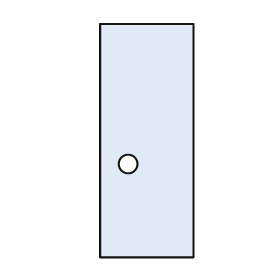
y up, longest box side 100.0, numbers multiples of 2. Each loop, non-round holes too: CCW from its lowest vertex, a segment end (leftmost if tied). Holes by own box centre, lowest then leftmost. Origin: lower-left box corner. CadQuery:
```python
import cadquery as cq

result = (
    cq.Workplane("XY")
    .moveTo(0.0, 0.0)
    .lineTo(40.0, 0.0)
    .lineTo(40.0, 100.0)
    .lineTo(0.0, 100.0)
    .close()
    .moveTo(12.0, 40.0)
    .circle(4.0)
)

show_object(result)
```